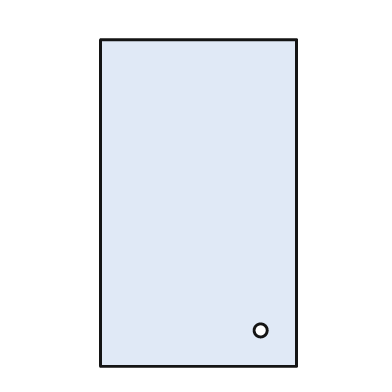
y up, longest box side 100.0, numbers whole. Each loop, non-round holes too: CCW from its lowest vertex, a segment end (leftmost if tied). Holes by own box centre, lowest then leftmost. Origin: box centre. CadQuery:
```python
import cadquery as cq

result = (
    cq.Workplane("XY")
    .moveTo(-30.0, -50.0)
    .lineTo(30.0, -50.0)
    .lineTo(30.0, 50.0)
    .lineTo(-30.0, 50.0)
    .close()
    .moveTo(19.0, -39.0)
    .circle(2.0)
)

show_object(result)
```